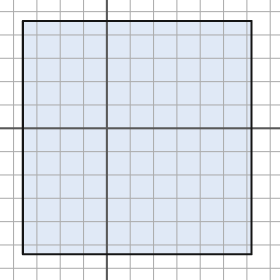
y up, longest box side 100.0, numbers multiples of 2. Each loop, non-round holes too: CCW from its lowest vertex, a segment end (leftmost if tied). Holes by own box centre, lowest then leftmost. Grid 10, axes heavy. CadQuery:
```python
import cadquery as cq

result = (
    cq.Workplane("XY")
    .moveTo(-36.0, -54.0)
    .lineTo(62.0, -54.0)
    .lineTo(62.0, 46.0)
    .lineTo(-36.0, 46.0)
    .close()
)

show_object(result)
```